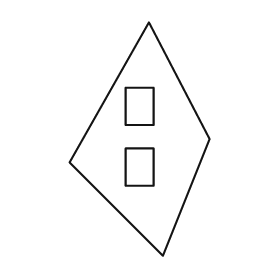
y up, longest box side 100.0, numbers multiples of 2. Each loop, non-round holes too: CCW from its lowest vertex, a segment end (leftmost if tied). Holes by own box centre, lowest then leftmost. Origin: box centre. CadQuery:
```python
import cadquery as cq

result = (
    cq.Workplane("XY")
    .moveTo(10.0, -50.0)
    .lineTo(30.0, 0.0)
    .lineTo(4.0, 50.0)
    .lineTo(-30.0, -10.0)
    .close()
    .moveTo(-6.0, -20.0)
    .lineTo(6.0, -20.0)
    .lineTo(6.0, -4.0)
    .lineTo(-6.0, -4.0)
    .close()
    .moveTo(-6.0, 6.0)
    .lineTo(6.0, 6.0)
    .lineTo(6.0, 22.0)
    .lineTo(-6.0, 22.0)
    .close()
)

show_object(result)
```